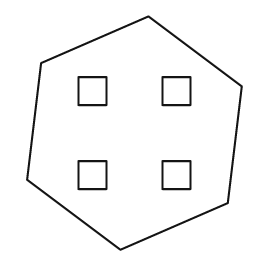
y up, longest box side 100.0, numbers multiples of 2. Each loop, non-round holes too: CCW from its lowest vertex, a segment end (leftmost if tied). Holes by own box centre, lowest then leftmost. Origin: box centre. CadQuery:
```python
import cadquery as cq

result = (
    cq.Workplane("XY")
    .moveTo(-6.0, -50.0)
    .lineTo(40.0, -30.0)
    .lineTo(46.0, 20.0)
    .lineTo(6.0, 50.0)
    .lineTo(-40.0, 30.0)
    .lineTo(-46.0, -20.0)
    .close()
    .moveTo(-24.0, -24.0)
    .lineTo(-12.0, -24.0)
    .lineTo(-12.0, -12.0)
    .lineTo(-24.0, -12.0)
    .close()
    .moveTo(12.0, -24.0)
    .lineTo(24.0, -24.0)
    .lineTo(24.0, -12.0)
    .lineTo(12.0, -12.0)
    .close()
    .moveTo(-24.0, 12.0)
    .lineTo(-12.0, 12.0)
    .lineTo(-12.0, 24.0)
    .lineTo(-24.0, 24.0)
    .close()
    .moveTo(12.0, 12.0)
    .lineTo(24.0, 12.0)
    .lineTo(24.0, 24.0)
    .lineTo(12.0, 24.0)
    .close()
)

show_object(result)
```